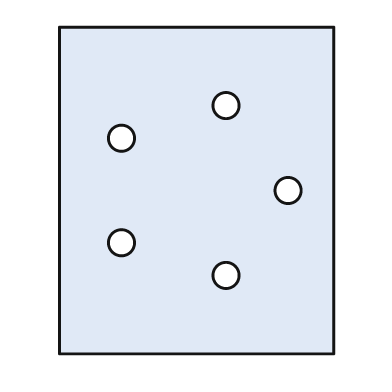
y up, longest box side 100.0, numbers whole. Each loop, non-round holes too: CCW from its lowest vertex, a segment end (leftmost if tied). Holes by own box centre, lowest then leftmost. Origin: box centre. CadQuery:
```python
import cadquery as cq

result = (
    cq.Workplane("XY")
    .moveTo(-42.0, -50.0)
    .lineTo(42.0, -50.0)
    .lineTo(42.0, 50.0)
    .lineTo(-42.0, 50.0)
    .close()
    .moveTo(9.0, -26.0)
    .circle(4.0)
    .moveTo(-23.0, -16.0)
    .circle(4.0)
    .moveTo(28.0, 0.0)
    .circle(4.0)
    .moveTo(-23.0, 16.0)
    .circle(4.0)
    .moveTo(9.0, 26.0)
    .circle(4.0)
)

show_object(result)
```